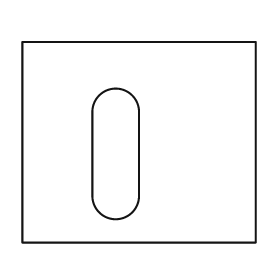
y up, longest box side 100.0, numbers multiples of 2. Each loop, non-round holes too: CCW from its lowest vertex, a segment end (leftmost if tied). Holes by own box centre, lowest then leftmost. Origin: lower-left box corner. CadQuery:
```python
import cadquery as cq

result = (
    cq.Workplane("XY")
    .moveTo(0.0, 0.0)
    .lineTo(100.0, 0.0)
    .lineTo(100.0, 86.0)
    .lineTo(0.0, 86.0)
    .close()
    .moveTo(30.0, 20.0)
    .threePointArc((40.0, 10.0), (50.0, 20.0))
    .lineTo(50.0, 56.0)
    .threePointArc((40.0, 66.0), (30.0, 56.0))
    .close()
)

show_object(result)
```